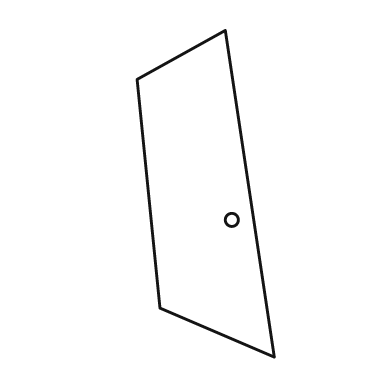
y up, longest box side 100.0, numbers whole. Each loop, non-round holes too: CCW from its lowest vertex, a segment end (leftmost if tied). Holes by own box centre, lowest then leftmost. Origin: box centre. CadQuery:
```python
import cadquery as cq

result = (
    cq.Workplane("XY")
    .moveTo(21.0, -50.0)
    .lineTo(6.0, 50.0)
    .lineTo(-21.0, 35.0)
    .lineTo(-14.0, -35.0)
    .close()
    .moveTo(8.0, -8.0)
    .circle(2.0)
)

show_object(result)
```